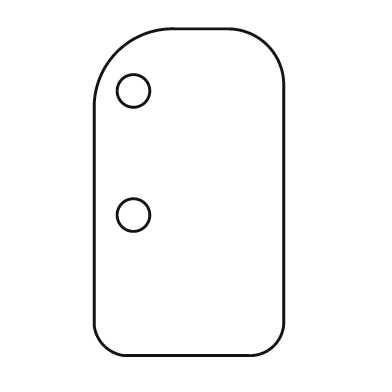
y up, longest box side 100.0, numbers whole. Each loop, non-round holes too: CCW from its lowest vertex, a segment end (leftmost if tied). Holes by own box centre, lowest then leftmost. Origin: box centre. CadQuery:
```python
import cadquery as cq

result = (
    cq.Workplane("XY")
    .moveTo(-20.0, -50.0)
    .lineTo(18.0, -50.0)
    .threePointArc((26.0, -47.0), (29.0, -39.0))
    .lineTo(29.0, 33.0)
    .threePointArc((24.0, 45.0), (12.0, 50.0))
    .lineTo(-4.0, 50.0)
    .threePointArc((-22.0, 43.0), (-29.0, 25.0))
    .lineTo(-29.0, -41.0)
    .threePointArc((-26.0, -47.0), (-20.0, -50.0))
    .close()
    .moveTo(-17.0, -7.0)
    .circle(5.0)
    .moveTo(-17.0, 31.0)
    .circle(5.0)
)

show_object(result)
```